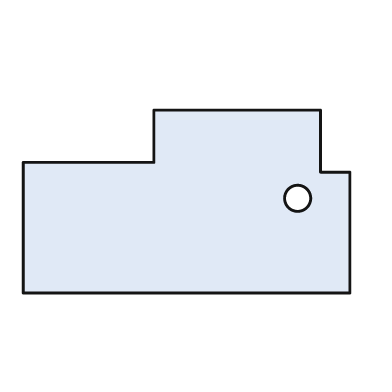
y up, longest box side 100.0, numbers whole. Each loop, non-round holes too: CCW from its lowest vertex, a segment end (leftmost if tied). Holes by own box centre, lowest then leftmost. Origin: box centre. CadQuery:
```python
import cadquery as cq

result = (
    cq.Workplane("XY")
    .moveTo(-50.0, -28.0)
    .lineTo(50.0, -28.0)
    .lineTo(50.0, 9.0)
    .lineTo(41.0, 9.0)
    .lineTo(41.0, 28.0)
    .lineTo(-10.0, 28.0)
    .lineTo(-10.0, 12.0)
    .lineTo(-50.0, 12.0)
    .close()
    .moveTo(34.0, 1.0)
    .circle(4.0)
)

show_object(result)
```